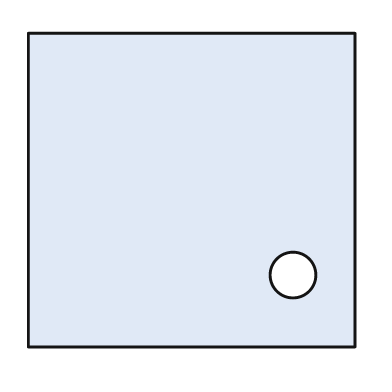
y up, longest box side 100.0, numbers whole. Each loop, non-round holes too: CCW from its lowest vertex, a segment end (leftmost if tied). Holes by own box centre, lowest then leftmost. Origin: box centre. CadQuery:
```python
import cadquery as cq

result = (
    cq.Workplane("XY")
    .moveTo(-50.0, -48.0)
    .lineTo(50.0, -48.0)
    .lineTo(50.0, 48.0)
    .lineTo(-50.0, 48.0)
    .close()
    .moveTo(31.0, -26.0)
    .circle(7.0)
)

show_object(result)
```